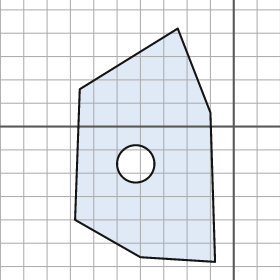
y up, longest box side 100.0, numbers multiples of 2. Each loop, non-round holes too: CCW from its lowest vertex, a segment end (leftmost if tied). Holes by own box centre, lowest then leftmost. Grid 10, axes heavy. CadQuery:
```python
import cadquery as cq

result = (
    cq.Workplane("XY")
    .moveTo(-8.0, -58.0)
    .lineTo(-10.0, 6.0)
    .lineTo(-24.0, 42.0)
    .lineTo(-66.0, 16.0)
    .lineTo(-68.0, -40.0)
    .lineTo(-40.0, -56.0)
    .close()
    .moveTo(-42.0, -16.0)
    .circle(8.0)
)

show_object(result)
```